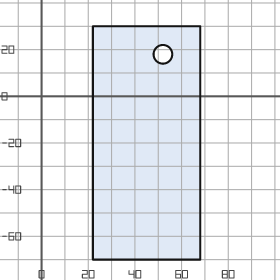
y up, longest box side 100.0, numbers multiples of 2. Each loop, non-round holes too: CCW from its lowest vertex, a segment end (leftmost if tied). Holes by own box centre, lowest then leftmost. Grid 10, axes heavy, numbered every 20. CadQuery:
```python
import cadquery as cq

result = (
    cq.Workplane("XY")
    .moveTo(22.0, -70.0)
    .lineTo(68.0, -70.0)
    .lineTo(68.0, 30.0)
    .lineTo(22.0, 30.0)
    .close()
    .moveTo(52.0, 18.0)
    .circle(4.0)
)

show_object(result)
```